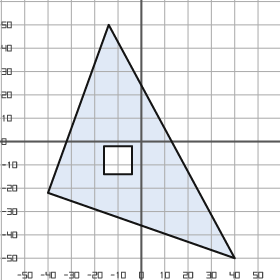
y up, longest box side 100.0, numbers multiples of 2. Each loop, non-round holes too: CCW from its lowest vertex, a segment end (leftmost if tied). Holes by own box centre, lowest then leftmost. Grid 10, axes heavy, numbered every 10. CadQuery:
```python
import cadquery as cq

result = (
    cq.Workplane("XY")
    .moveTo(40.0, -50.0)
    .lineTo(-14.0, 50.0)
    .lineTo(-40.0, -22.0)
    .close()
    .moveTo(-16.0, -14.0)
    .lineTo(-4.0, -14.0)
    .lineTo(-4.0, -2.0)
    .lineTo(-16.0, -2.0)
    .close()
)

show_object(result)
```